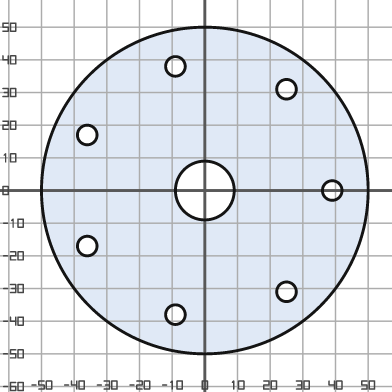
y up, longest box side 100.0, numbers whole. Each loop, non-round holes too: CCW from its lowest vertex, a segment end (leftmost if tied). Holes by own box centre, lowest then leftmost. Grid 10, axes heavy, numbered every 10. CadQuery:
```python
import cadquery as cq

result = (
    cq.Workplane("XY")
    .moveTo(0.0, 0.0)
    .circle(50.0)
    .moveTo(-9.0, -38.0)
    .circle(3.0)
    .moveTo(25.0, -31.0)
    .circle(3.0)
    .moveTo(-36.0, -17.0)
    .circle(3.0)
    .moveTo(0.0, 0.0)
    .circle(9.0)
    .moveTo(39.0, 0.0)
    .circle(3.0)
    .moveTo(-36.0, 17.0)
    .circle(3.0)
    .moveTo(25.0, 31.0)
    .circle(3.0)
    .moveTo(-9.0, 38.0)
    .circle(3.0)
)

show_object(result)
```